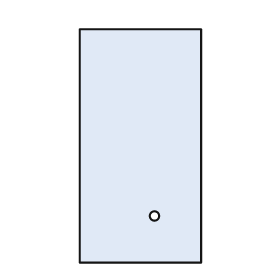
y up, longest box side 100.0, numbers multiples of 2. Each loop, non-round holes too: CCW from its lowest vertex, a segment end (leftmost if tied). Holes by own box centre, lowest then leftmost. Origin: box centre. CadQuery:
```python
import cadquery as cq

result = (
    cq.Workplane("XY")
    .moveTo(-26.0, -50.0)
    .lineTo(26.0, -50.0)
    .lineTo(26.0, 50.0)
    .lineTo(-26.0, 50.0)
    .close()
    .moveTo(6.0, -30.0)
    .circle(2.0)
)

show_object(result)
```